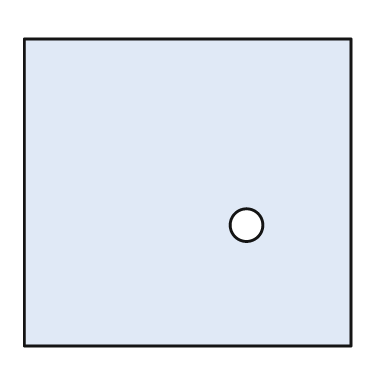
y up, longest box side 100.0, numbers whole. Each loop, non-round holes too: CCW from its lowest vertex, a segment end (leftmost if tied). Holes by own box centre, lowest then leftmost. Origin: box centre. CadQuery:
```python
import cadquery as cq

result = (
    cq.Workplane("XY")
    .moveTo(-50.0, -47.0)
    .lineTo(50.0, -47.0)
    .lineTo(50.0, 47.0)
    .lineTo(-50.0, 47.0)
    .close()
    .moveTo(18.0, -10.0)
    .circle(5.0)
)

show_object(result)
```